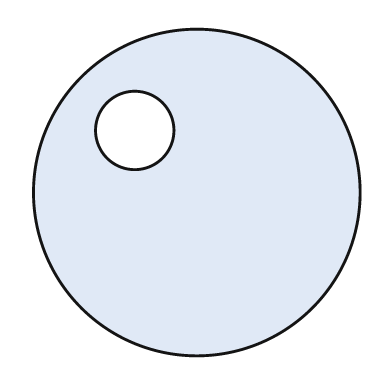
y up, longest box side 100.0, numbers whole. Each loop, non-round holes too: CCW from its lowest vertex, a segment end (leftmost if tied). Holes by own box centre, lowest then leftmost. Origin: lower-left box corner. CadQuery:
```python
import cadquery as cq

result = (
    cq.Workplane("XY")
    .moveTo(50.0, 50.0)
    .circle(50.0)
    .moveTo(31.0, 69.0)
    .circle(12.0)
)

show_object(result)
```